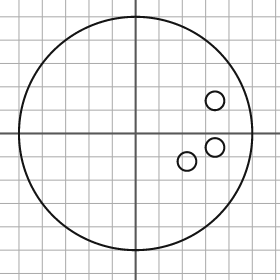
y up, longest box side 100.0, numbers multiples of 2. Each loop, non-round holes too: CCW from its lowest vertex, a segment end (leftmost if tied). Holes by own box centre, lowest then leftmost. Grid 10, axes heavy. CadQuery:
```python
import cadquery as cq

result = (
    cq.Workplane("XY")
    .moveTo(0.0, 0.0)
    .circle(50.0)
    .moveTo(22.0, -12.0)
    .circle(4.0)
    .moveTo(34.0, -6.0)
    .circle(4.0)
    .moveTo(34.0, 14.0)
    .circle(4.0)
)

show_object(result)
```